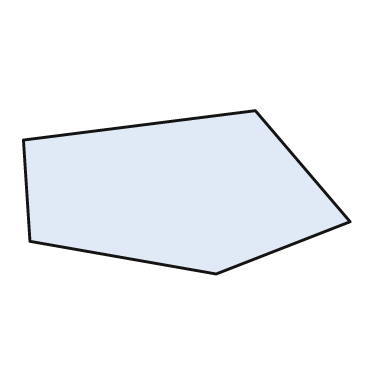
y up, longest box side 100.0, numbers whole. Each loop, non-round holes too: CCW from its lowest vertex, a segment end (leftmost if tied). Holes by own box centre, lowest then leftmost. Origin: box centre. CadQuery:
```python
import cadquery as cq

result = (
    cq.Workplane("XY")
    .moveTo(9.0, -25.0)
    .lineTo(50.0, -9.0)
    .lineTo(21.0, 25.0)
    .lineTo(-50.0, 16.0)
    .lineTo(-48.0, -15.0)
    .close()
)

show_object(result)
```